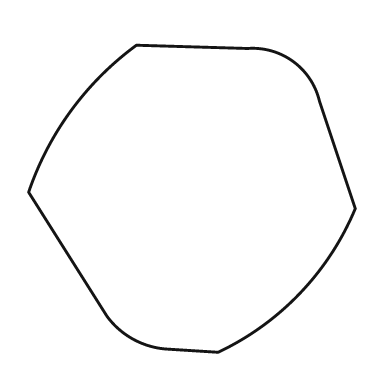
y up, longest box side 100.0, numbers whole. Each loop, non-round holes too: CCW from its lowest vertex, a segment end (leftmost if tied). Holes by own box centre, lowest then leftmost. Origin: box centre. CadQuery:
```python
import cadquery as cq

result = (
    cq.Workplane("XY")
    .moveTo(8.0, -47.0)
    .threePointArc((33.0, -29.0), (50.0, -3.0))
    .lineTo(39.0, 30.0)
    .threePointArc((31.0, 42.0), (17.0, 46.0))
    .lineTo(-17.0, 47.0)
    .threePointArc((-37.0, 27.0), (-50.0, 2.0))
    .lineTo(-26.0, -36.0)
    .threePointArc((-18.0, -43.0), (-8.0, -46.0))
    .close()
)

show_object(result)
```